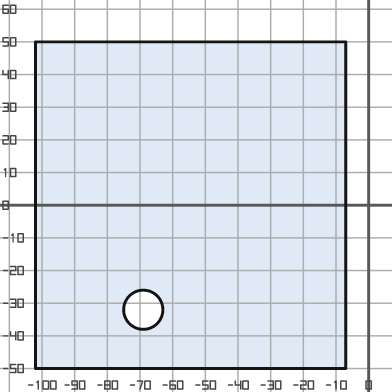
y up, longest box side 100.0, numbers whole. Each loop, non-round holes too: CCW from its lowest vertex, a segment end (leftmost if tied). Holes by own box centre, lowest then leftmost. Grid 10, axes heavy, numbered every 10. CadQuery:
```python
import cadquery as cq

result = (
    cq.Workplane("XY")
    .moveTo(-102.0, -50.0)
    .lineTo(-7.0, -50.0)
    .lineTo(-7.0, 50.0)
    .lineTo(-102.0, 50.0)
    .close()
    .moveTo(-69.0, -32.0)
    .circle(6.0)
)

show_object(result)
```